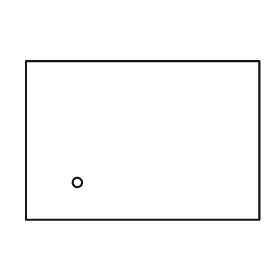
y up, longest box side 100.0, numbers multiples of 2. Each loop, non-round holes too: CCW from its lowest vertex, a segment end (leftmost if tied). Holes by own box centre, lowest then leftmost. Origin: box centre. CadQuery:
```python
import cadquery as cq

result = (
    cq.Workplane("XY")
    .moveTo(-50.0, -34.0)
    .lineTo(50.0, -34.0)
    .lineTo(50.0, 34.0)
    .lineTo(-50.0, 34.0)
    .close()
    .moveTo(-28.0, -18.0)
    .circle(2.0)
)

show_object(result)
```